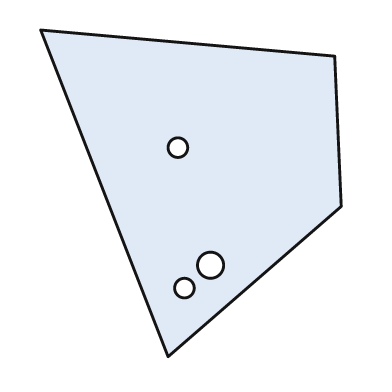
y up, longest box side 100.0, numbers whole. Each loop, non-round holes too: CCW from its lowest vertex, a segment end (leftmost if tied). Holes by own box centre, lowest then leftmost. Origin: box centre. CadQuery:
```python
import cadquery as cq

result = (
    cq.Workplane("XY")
    .moveTo(-7.0, -50.0)
    .lineTo(46.0, -4.0)
    .lineTo(44.0, 42.0)
    .lineTo(-46.0, 50.0)
    .close()
    .moveTo(-2.0, -29.0)
    .circle(3.0)
    .moveTo(6.0, -22.0)
    .circle(4.0)
    .moveTo(-4.0, 14.0)
    .circle(3.0)
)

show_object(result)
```